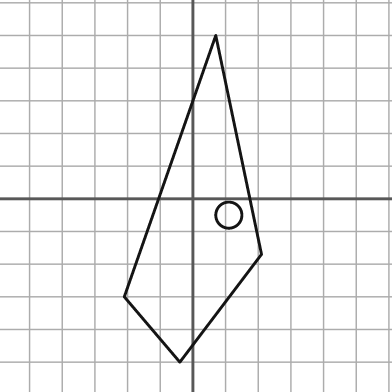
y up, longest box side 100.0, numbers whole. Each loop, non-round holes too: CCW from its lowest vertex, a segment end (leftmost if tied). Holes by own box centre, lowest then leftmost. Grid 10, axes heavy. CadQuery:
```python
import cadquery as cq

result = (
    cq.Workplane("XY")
    .moveTo(-4.0, -50.0)
    .lineTo(21.0, -17.0)
    .lineTo(7.0, 50.0)
    .lineTo(-21.0, -30.0)
    .close()
    .moveTo(11.0, -5.0)
    .circle(4.0)
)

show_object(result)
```